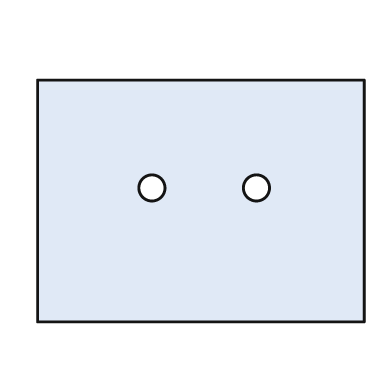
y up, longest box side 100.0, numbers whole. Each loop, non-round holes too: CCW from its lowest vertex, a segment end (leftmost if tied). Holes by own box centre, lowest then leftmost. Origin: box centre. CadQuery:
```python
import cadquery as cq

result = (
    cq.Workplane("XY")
    .moveTo(-50.0, -37.0)
    .lineTo(50.0, -37.0)
    .lineTo(50.0, 37.0)
    .lineTo(-50.0, 37.0)
    .close()
    .moveTo(-15.0, 4.0)
    .circle(4.0)
    .moveTo(17.0, 4.0)
    .circle(4.0)
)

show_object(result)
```